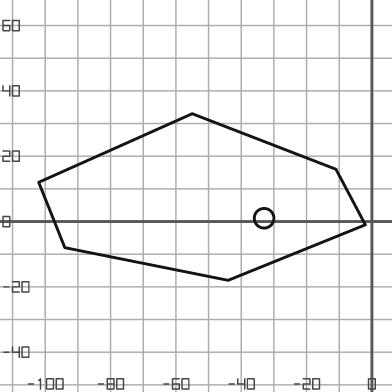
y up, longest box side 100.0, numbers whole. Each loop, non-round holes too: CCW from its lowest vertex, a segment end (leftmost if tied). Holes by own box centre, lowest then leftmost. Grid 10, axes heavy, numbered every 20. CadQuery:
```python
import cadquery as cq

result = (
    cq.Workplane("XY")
    .moveTo(-44.0, -18.0)
    .lineTo(-2.0, -1.0)
    .lineTo(-11.0, 16.0)
    .lineTo(-55.0, 33.0)
    .lineTo(-102.0, 12.0)
    .lineTo(-94.0, -8.0)
    .close()
    .moveTo(-33.0, 1.0)
    .circle(3.0)
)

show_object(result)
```